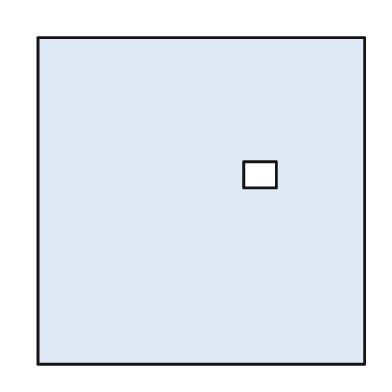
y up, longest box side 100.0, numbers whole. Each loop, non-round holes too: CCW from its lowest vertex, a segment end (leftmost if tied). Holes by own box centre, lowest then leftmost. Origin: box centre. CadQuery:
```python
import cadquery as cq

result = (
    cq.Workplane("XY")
    .moveTo(-50.0, -50.0)
    .lineTo(50.0, -50.0)
    .lineTo(50.0, 50.0)
    .lineTo(-50.0, 50.0)
    .close()
    .moveTo(13.0, 4.0)
    .lineTo(23.0, 4.0)
    .lineTo(23.0, 12.0)
    .lineTo(13.0, 12.0)
    .close()
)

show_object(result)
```